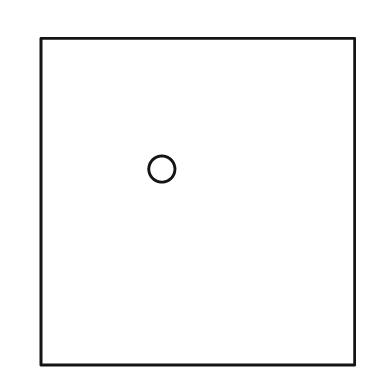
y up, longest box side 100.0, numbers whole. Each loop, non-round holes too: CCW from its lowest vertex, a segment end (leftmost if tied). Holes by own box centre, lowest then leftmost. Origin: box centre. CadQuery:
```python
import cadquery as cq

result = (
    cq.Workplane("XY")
    .moveTo(-48.0, -50.0)
    .lineTo(48.0, -50.0)
    .lineTo(48.0, 50.0)
    .lineTo(-48.0, 50.0)
    .close()
    .moveTo(-11.0, 10.0)
    .circle(4.0)
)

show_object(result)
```